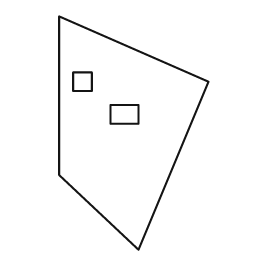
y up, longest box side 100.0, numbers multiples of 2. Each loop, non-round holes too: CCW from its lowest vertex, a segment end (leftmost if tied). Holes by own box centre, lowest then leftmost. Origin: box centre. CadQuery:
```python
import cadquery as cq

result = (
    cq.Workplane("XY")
    .moveTo(2.0, -50.0)
    .lineTo(32.0, 22.0)
    .lineTo(-32.0, 50.0)
    .lineTo(-32.0, -18.0)
    .close()
    .moveTo(-10.0, 4.0)
    .lineTo(2.0, 4.0)
    .lineTo(2.0, 12.0)
    .lineTo(-10.0, 12.0)
    .close()
    .moveTo(-26.0, 18.0)
    .lineTo(-18.0, 18.0)
    .lineTo(-18.0, 26.0)
    .lineTo(-26.0, 26.0)
    .close()
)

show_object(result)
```